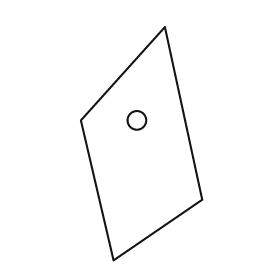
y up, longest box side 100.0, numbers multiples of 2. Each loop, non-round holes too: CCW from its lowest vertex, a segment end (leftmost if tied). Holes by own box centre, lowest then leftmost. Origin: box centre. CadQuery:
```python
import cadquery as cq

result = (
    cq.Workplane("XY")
    .moveTo(-12.0, -50.0)
    .lineTo(26.0, -24.0)
    .lineTo(10.0, 50.0)
    .lineTo(-26.0, 10.0)
    .close()
    .moveTo(-2.0, 10.0)
    .circle(4.0)
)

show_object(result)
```